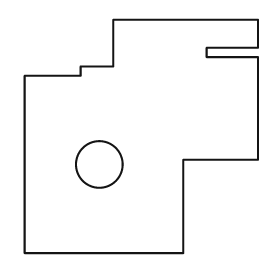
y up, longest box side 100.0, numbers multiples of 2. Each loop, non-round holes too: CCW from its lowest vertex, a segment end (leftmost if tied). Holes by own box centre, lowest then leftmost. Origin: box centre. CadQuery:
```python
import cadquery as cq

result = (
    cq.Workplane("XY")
    .moveTo(-50.0, -50.0)
    .lineTo(18.0, -50.0)
    .lineTo(18.0, -10.0)
    .lineTo(50.0, -10.0)
    .lineTo(50.0, 34.0)
    .lineTo(28.0, 34.0)
    .lineTo(28.0, 38.0)
    .lineTo(50.0, 38.0)
    .lineTo(50.0, 50.0)
    .lineTo(-12.0, 50.0)
    .lineTo(-12.0, 30.0)
    .lineTo(-26.0, 30.0)
    .lineTo(-26.0, 26.0)
    .lineTo(-50.0, 26.0)
    .close()
    .moveTo(-18.0, -12.0)
    .circle(10.0)
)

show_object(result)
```